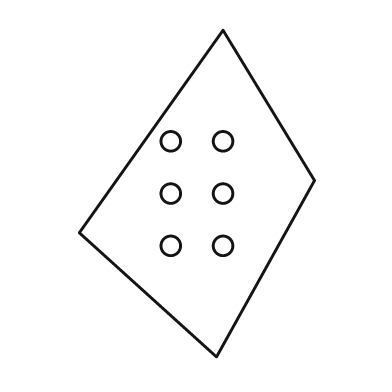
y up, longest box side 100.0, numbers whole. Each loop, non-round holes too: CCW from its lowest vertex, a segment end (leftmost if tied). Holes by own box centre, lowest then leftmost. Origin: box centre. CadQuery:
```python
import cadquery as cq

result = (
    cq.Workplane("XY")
    .moveTo(6.0, -50.0)
    .lineTo(36.0, 4.0)
    .lineTo(8.0, 50.0)
    .lineTo(-36.0, -12.0)
    .close()
    .moveTo(-8.0, -16.0)
    .circle(3.0)
    .moveTo(8.0, -16.0)
    .circle(3.0)
    .moveTo(-8.0, 0.0)
    .circle(3.0)
    .moveTo(8.0, 0.0)
    .circle(3.0)
    .moveTo(-8.0, 16.0)
    .circle(3.0)
    .moveTo(8.0, 16.0)
    .circle(3.0)
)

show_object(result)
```